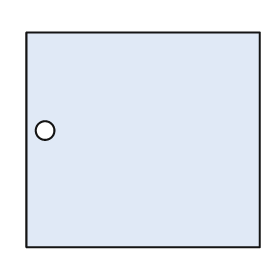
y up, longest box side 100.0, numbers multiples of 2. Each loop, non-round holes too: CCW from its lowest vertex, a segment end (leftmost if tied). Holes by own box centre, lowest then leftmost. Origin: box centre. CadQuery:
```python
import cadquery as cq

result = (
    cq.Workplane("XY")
    .moveTo(-50.0, -46.0)
    .lineTo(50.0, -46.0)
    .lineTo(50.0, 46.0)
    .lineTo(-50.0, 46.0)
    .close()
    .moveTo(-42.0, 4.0)
    .circle(4.0)
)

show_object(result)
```